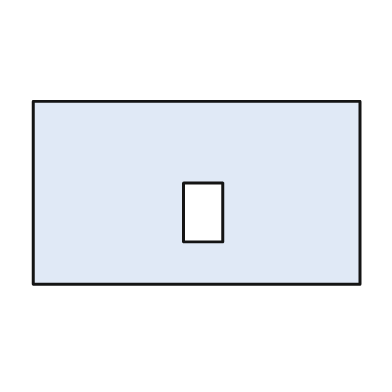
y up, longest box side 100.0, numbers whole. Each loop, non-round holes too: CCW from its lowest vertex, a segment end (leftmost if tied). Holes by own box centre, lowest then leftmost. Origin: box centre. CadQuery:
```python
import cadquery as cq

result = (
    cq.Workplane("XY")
    .moveTo(-50.0, -28.0)
    .lineTo(50.0, -28.0)
    .lineTo(50.0, 28.0)
    .lineTo(-50.0, 28.0)
    .close()
    .moveTo(-4.0, -15.0)
    .lineTo(8.0, -15.0)
    .lineTo(8.0, 3.0)
    .lineTo(-4.0, 3.0)
    .close()
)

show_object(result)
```